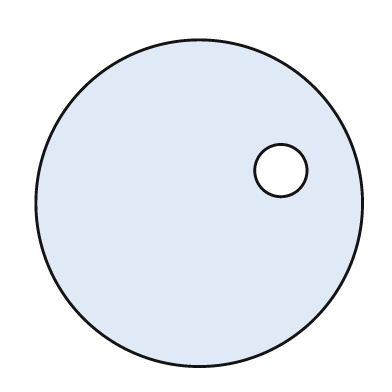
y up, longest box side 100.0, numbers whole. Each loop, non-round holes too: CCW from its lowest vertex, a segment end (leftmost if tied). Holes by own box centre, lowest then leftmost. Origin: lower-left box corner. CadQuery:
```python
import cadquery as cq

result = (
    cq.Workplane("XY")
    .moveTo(50.0, 50.0)
    .circle(50.0)
    .moveTo(75.0, 60.0)
    .circle(8.0)
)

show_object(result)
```